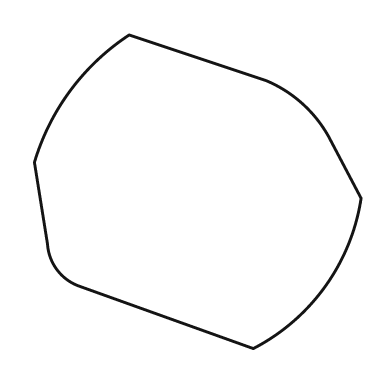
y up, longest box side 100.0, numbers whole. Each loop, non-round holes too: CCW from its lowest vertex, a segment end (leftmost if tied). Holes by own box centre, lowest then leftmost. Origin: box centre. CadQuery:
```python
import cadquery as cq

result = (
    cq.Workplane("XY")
    .moveTo(17.0, -48.0)
    .threePointArc((39.0, -29.0), (50.0, -2.0))
    .lineTo(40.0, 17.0)
    .threePointArc((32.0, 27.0), (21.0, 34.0))
    .lineTo(-21.0, 48.0)
    .threePointArc((-39.0, 31.0), (-50.0, 9.0))
    .lineTo(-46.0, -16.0)
    .threePointArc((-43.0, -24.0), (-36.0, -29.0))
    .close()
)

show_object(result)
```